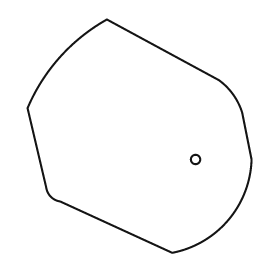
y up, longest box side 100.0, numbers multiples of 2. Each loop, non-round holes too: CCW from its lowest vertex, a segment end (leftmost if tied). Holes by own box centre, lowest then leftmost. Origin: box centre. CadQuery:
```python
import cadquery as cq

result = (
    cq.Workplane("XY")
    .moveTo(14.0, -50.0)
    .threePointArc((38.0, -36.0), (48.0, -10.0))
    .lineTo(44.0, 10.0)
    .threePointArc((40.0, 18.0), (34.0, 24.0))
    .lineTo(-14.0, 50.0)
    .threePointArc((-34.0, 34.0), (-48.0, 12.0))
    .lineTo(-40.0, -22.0)
    .threePointArc((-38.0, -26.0), (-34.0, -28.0))
    .close()
    .moveTo(24.0, -10.0)
    .circle(2.0)
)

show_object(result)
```